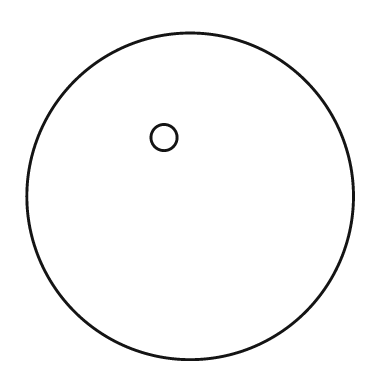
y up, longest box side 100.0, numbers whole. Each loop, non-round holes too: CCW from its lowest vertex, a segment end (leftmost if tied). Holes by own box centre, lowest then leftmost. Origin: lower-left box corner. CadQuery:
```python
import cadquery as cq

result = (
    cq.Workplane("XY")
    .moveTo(50.0, 50.0)
    .circle(50.0)
    .moveTo(42.0, 68.0)
    .circle(4.0)
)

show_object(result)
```